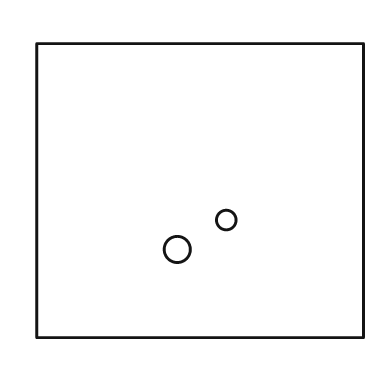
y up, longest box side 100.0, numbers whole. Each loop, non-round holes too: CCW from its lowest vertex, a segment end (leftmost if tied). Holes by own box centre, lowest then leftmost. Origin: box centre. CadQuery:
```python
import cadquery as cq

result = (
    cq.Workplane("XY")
    .moveTo(-50.0, -45.0)
    .lineTo(50.0, -45.0)
    .lineTo(50.0, 45.0)
    .lineTo(-50.0, 45.0)
    .close()
    .moveTo(-7.0, -18.0)
    .circle(4.0)
    .moveTo(8.0, -9.0)
    .circle(3.0)
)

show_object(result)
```